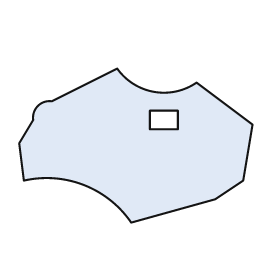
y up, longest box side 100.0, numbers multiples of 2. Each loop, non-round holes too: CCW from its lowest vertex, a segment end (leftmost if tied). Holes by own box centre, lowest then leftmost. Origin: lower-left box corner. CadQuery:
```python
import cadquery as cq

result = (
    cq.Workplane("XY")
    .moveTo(48.0, 0.0)
    .lineTo(84.0, 10.0)
    .lineTo(96.0, 18.0)
    .lineTo(100.0, 42.0)
    .lineTo(76.0, 60.0)
    .threePointArc((58.0, 56.0), (42.0, 66.0))
    .lineTo(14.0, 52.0)
    .threePointArc((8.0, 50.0), (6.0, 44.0))
    .lineTo(0.0, 34.0)
    .lineTo(2.0, 18.0)
    .threePointArc((28.0, 16.0), (48.0, 0.0))
    .close()
    .moveTo(56.0, 40.0)
    .lineTo(68.0, 40.0)
    .lineTo(68.0, 48.0)
    .lineTo(56.0, 48.0)
    .close()
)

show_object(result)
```